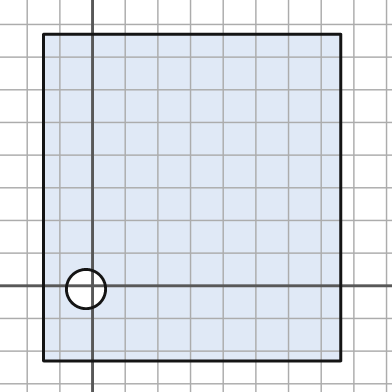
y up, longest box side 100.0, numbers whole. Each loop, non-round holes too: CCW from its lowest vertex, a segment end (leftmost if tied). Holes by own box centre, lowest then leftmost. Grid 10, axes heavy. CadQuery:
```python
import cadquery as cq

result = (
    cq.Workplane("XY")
    .moveTo(-15.0, -23.0)
    .lineTo(76.0, -23.0)
    .lineTo(76.0, 77.0)
    .lineTo(-15.0, 77.0)
    .close()
    .moveTo(-2.0, -1.0)
    .circle(6.0)
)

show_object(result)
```